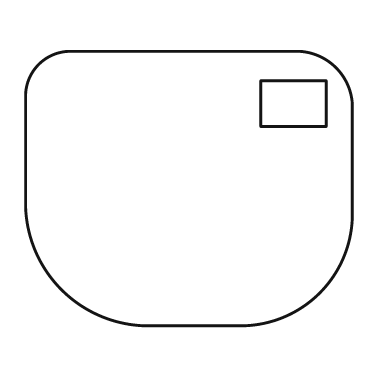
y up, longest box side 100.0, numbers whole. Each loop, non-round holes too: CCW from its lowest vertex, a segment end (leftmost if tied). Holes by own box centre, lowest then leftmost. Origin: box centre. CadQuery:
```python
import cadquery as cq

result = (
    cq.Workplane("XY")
    .moveTo(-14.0, -42.0)
    .lineTo(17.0, -42.0)
    .threePointArc((40.0, -32.0), (50.0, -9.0))
    .lineTo(50.0, 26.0)
    .threePointArc((45.0, 37.0), (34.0, 42.0))
    .lineTo(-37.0, 42.0)
    .threePointArc((-46.0, 38.0), (-50.0, 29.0))
    .lineTo(-50.0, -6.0)
    .threePointArc((-39.0, -31.0), (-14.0, -42.0))
    .close()
    .moveTo(22.0, 19.0)
    .lineTo(42.0, 19.0)
    .lineTo(42.0, 33.0)
    .lineTo(22.0, 33.0)
    .close()
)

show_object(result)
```